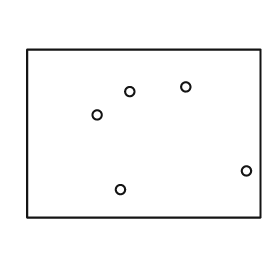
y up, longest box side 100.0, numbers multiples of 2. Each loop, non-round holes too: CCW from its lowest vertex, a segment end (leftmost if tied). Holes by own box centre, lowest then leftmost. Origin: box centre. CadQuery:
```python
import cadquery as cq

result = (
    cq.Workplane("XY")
    .moveTo(-50.0, -36.0)
    .lineTo(50.0, -36.0)
    .lineTo(50.0, 36.0)
    .lineTo(-50.0, 36.0)
    .close()
    .moveTo(-10.0, -24.0)
    .circle(2.0)
    .moveTo(44.0, -16.0)
    .circle(2.0)
    .moveTo(-20.0, 8.0)
    .circle(2.0)
    .moveTo(-6.0, 18.0)
    .circle(2.0)
    .moveTo(18.0, 20.0)
    .circle(2.0)
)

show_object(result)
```